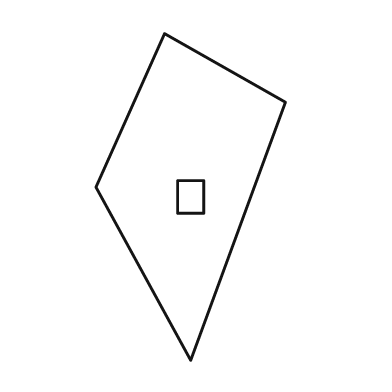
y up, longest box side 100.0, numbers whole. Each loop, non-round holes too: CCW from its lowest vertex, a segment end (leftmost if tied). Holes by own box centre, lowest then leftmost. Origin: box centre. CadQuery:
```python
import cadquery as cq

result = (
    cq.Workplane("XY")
    .moveTo(0.0, -50.0)
    .lineTo(29.0, 29.0)
    .lineTo(-8.0, 50.0)
    .lineTo(-29.0, 3.0)
    .close()
    .moveTo(-4.0, -5.0)
    .lineTo(4.0, -5.0)
    .lineTo(4.0, 5.0)
    .lineTo(-4.0, 5.0)
    .close()
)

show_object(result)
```